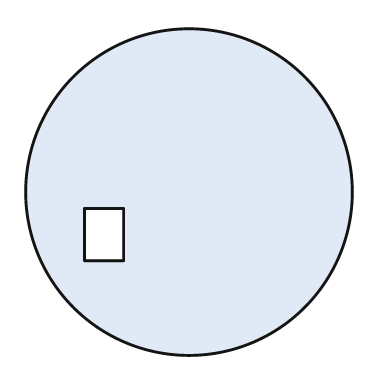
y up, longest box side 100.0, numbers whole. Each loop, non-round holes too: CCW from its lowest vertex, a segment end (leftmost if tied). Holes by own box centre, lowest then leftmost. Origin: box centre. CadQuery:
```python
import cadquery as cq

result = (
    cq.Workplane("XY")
    .moveTo(0.0, 0.0)
    .circle(50.0)
    .moveTo(-32.0, -21.0)
    .lineTo(-20.0, -21.0)
    .lineTo(-20.0, -5.0)
    .lineTo(-32.0, -5.0)
    .close()
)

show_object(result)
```